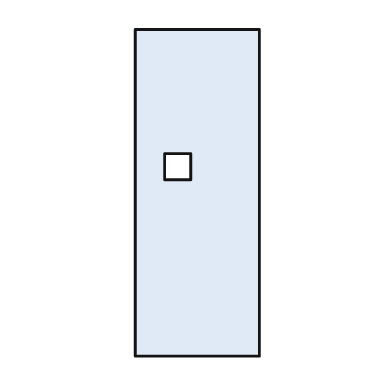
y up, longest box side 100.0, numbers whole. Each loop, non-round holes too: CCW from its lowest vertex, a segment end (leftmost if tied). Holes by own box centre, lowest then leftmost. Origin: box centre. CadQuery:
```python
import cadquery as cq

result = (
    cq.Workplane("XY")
    .moveTo(-19.0, -50.0)
    .lineTo(19.0, -50.0)
    .lineTo(19.0, 50.0)
    .lineTo(-19.0, 50.0)
    .close()
    .moveTo(-10.0, 4.0)
    .lineTo(-2.0, 4.0)
    .lineTo(-2.0, 12.0)
    .lineTo(-10.0, 12.0)
    .close()
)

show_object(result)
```